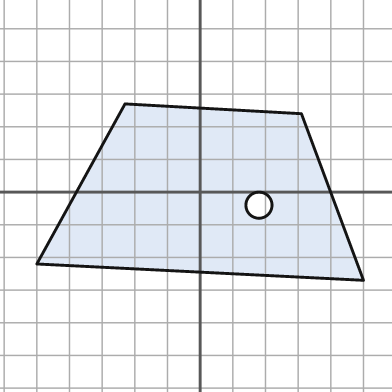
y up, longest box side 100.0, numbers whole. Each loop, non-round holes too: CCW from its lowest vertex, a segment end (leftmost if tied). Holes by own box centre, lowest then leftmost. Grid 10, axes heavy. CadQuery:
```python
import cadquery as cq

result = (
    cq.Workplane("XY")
    .moveTo(50.0, -27.0)
    .lineTo(31.0, 24.0)
    .lineTo(-23.0, 27.0)
    .lineTo(-50.0, -22.0)
    .close()
    .moveTo(18.0, -4.0)
    .circle(4.0)
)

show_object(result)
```